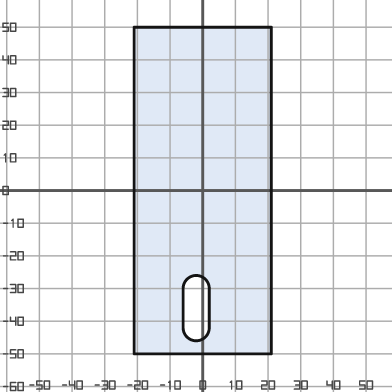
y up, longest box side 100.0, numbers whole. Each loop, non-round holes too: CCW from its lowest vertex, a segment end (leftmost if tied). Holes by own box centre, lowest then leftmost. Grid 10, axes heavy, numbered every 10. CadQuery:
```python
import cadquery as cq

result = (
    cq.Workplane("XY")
    .moveTo(-21.0, -50.0)
    .lineTo(21.0, -50.0)
    .lineTo(21.0, 50.0)
    .lineTo(-21.0, 50.0)
    .close()
    .moveTo(-6.0, -42.0)
    .threePointArc((-2.0, -46.0), (2.0, -42.0))
    .lineTo(2.0, -30.0)
    .threePointArc((-2.0, -26.0), (-6.0, -30.0))
    .close()
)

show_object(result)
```